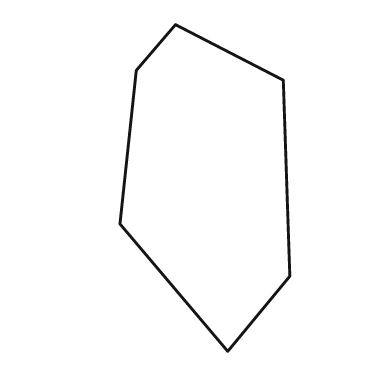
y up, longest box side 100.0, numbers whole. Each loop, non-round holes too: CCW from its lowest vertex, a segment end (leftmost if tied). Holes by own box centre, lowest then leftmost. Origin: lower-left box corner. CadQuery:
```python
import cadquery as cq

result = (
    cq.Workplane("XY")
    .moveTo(33.0, 0.0)
    .lineTo(52.0, 23.0)
    .lineTo(50.0, 83.0)
    .lineTo(17.0, 100.0)
    .lineTo(5.0, 86.0)
    .lineTo(0.0, 39.0)
    .close()
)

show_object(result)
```